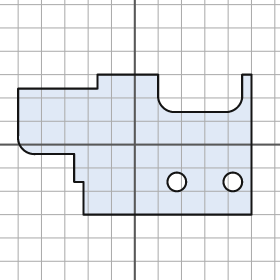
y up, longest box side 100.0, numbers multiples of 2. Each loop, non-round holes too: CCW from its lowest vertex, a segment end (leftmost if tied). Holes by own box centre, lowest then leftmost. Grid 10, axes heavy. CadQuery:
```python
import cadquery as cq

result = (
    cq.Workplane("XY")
    .moveTo(-22.0, -30.0)
    .lineTo(50.0, -30.0)
    .lineTo(50.0, 30.0)
    .lineTo(46.0, 30.0)
    .lineTo(46.0, 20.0)
    .threePointArc((44.0, 16.0), (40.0, 14.0))
    .lineTo(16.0, 14.0)
    .threePointArc((12.0, 16.0), (10.0, 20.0))
    .lineTo(10.0, 30.0)
    .lineTo(-16.0, 30.0)
    .lineTo(-16.0, 24.0)
    .lineTo(-50.0, 24.0)
    .lineTo(-50.0, 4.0)
    .threePointArc((-48.0, -2.0), (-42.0, -4.0))
    .lineTo(-26.0, -4.0)
    .lineTo(-26.0, -16.0)
    .lineTo(-22.0, -16.0)
    .close()
    .moveTo(18.0, -16.0)
    .circle(4.0)
    .moveTo(42.0, -16.0)
    .circle(4.0)
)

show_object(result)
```